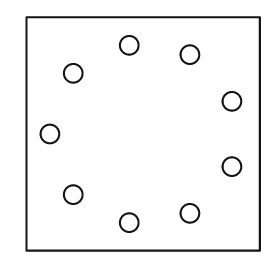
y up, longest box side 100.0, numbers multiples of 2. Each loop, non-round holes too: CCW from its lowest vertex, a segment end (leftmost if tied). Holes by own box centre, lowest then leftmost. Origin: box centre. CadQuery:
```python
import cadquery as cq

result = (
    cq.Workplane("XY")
    .moveTo(-50.0, -50.0)
    .lineTo(50.0, -50.0)
    .lineTo(50.0, 50.0)
    .lineTo(-50.0, 50.0)
    .close()
    .moveTo(-6.0, -38.0)
    .circle(4.0)
    .moveTo(20.0, -34.0)
    .circle(4.0)
    .moveTo(-30.0, -26.0)
    .circle(4.0)
    .moveTo(38.0, -14.0)
    .circle(4.0)
    .moveTo(-40.0, 0.0)
    .circle(4.0)
    .moveTo(38.0, 14.0)
    .circle(4.0)
    .moveTo(-30.0, 26.0)
    .circle(4.0)
    .moveTo(20.0, 34.0)
    .circle(4.0)
    .moveTo(-6.0, 38.0)
    .circle(4.0)
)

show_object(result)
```